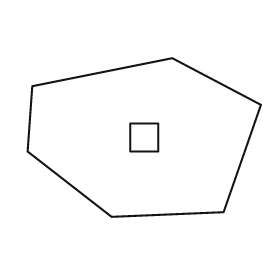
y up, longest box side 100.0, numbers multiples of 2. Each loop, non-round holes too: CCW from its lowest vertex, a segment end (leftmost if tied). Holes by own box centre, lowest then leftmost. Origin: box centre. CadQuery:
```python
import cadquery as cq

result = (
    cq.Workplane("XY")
    .moveTo(-14.0, -34.0)
    .lineTo(34.0, -32.0)
    .lineTo(50.0, 14.0)
    .lineTo(12.0, 34.0)
    .lineTo(-48.0, 22.0)
    .lineTo(-50.0, -6.0)
    .close()
    .moveTo(-6.0, -6.0)
    .lineTo(6.0, -6.0)
    .lineTo(6.0, 6.0)
    .lineTo(-6.0, 6.0)
    .close()
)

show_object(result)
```